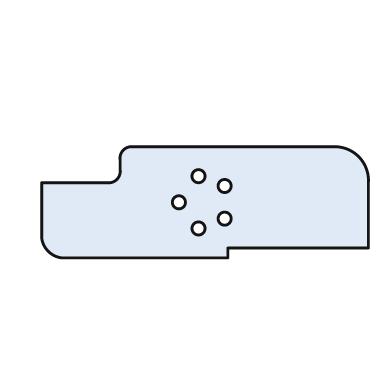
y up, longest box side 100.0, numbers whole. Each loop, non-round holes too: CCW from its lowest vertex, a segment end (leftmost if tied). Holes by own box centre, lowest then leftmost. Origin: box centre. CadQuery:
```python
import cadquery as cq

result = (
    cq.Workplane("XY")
    .moveTo(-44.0, -17.0)
    .lineTo(7.0, -17.0)
    .lineTo(7.0, -14.0)
    .lineTo(50.0, -14.0)
    .lineTo(50.0, 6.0)
    .threePointArc((47.0, 14.0), (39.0, 17.0))
    .lineTo(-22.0, 17.0)
    .threePointArc((-25.0, 16.0), (-26.0, 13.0))
    .lineTo(-26.0, 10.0)
    .threePointArc((-27.0, 7.0), (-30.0, 6.0))
    .lineTo(-50.0, 6.0)
    .lineTo(-50.0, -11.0)
    .threePointArc((-48.0, -15.0), (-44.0, -17.0))
    .close()
    .moveTo(-2.0, -8.0)
    .circle(2.0)
    .moveTo(6.0, -5.0)
    .circle(2.0)
    .moveTo(-8.0, 0.0)
    .circle(2.0)
    .moveTo(6.0, 5.0)
    .circle(2.0)
    .moveTo(-2.0, 8.0)
    .circle(2.0)
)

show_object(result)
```